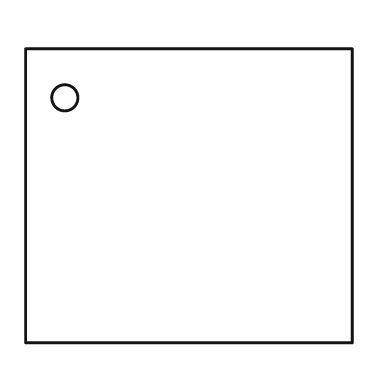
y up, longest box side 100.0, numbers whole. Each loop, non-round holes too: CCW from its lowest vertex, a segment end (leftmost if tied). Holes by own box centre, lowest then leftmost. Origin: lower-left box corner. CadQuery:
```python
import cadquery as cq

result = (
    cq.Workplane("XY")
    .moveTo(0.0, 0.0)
    .lineTo(100.0, 0.0)
    .lineTo(100.0, 90.0)
    .lineTo(0.0, 90.0)
    .close()
    .moveTo(12.0, 75.0)
    .circle(4.0)
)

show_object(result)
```